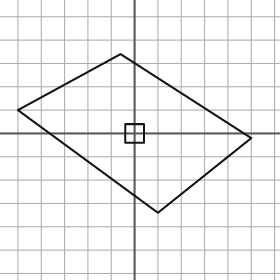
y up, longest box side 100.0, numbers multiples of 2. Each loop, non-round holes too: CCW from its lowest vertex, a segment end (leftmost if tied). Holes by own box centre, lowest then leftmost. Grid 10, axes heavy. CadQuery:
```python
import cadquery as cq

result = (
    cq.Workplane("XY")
    .moveTo(10.0, -34.0)
    .lineTo(50.0, -2.0)
    .lineTo(-6.0, 34.0)
    .lineTo(-50.0, 10.0)
    .close()
    .moveTo(-4.0, -4.0)
    .lineTo(4.0, -4.0)
    .lineTo(4.0, 4.0)
    .lineTo(-4.0, 4.0)
    .close()
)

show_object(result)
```